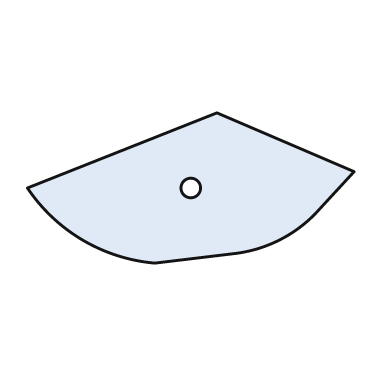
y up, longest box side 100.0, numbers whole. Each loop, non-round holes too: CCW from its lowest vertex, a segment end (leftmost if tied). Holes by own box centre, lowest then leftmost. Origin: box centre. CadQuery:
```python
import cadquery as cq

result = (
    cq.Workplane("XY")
    .moveTo(-11.0, -23.0)
    .lineTo(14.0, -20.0)
    .threePointArc((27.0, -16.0), (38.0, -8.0))
    .lineTo(50.0, 5.0)
    .lineTo(8.0, 23.0)
    .lineTo(-50.0, 0.0)
    .threePointArc((-33.0, -16.0), (-11.0, -23.0))
    .close()
    .moveTo(0.0, 0.0)
    .circle(3.0)
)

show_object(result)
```